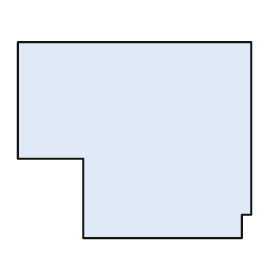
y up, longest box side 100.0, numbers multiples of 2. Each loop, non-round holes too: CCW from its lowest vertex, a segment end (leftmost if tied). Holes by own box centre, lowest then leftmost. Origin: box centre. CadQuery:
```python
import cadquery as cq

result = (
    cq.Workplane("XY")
    .moveTo(-22.0, -42.0)
    .lineTo(46.0, -42.0)
    .lineTo(46.0, -32.0)
    .lineTo(50.0, -32.0)
    .lineTo(50.0, 42.0)
    .lineTo(-50.0, 42.0)
    .lineTo(-50.0, -8.0)
    .lineTo(-22.0, -8.0)
    .close()
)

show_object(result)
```